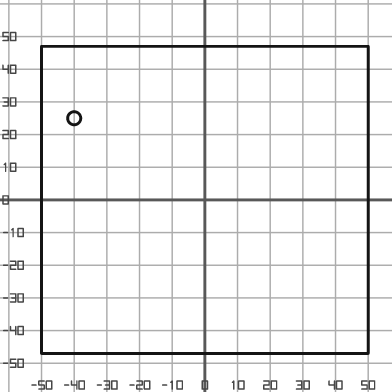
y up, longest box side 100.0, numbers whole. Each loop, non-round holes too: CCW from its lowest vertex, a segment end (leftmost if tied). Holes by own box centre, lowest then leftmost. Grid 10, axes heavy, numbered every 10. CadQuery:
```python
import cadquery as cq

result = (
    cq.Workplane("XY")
    .moveTo(-50.0, -47.0)
    .lineTo(50.0, -47.0)
    .lineTo(50.0, 47.0)
    .lineTo(-50.0, 47.0)
    .close()
    .moveTo(-40.0, 25.0)
    .circle(2.0)
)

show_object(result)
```